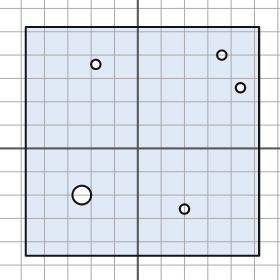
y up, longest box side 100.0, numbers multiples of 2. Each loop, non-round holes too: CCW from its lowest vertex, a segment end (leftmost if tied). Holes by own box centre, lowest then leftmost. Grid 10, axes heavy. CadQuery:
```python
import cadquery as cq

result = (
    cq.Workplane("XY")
    .moveTo(-48.0, -46.0)
    .lineTo(52.0, -46.0)
    .lineTo(52.0, 52.0)
    .lineTo(-48.0, 52.0)
    .close()
    .moveTo(20.0, -26.0)
    .circle(2.0)
    .moveTo(-24.0, -20.0)
    .circle(4.0)
    .moveTo(44.0, 26.0)
    .circle(2.0)
    .moveTo(-18.0, 36.0)
    .circle(2.0)
    .moveTo(36.0, 40.0)
    .circle(2.0)
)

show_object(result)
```